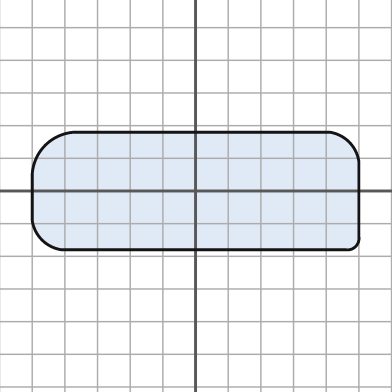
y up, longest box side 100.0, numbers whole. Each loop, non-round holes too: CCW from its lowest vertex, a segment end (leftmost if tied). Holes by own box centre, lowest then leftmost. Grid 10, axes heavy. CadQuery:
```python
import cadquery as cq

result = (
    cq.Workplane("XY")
    .moveTo(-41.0, -18.0)
    .lineTo(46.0, -18.0)
    .threePointArc((49.0, -17.0), (50.0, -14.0))
    .lineTo(50.0, 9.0)
    .threePointArc((47.0, 15.0), (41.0, 18.0))
    .lineTo(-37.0, 18.0)
    .threePointArc((-46.0, 14.0), (-50.0, 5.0))
    .lineTo(-50.0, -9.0)
    .threePointArc((-47.0, -15.0), (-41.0, -18.0))
    .close()
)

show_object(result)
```